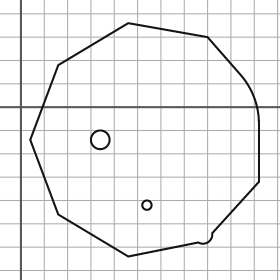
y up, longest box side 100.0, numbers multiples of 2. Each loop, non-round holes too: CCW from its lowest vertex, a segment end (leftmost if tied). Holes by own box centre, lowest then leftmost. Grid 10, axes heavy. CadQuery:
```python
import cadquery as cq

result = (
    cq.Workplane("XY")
    .moveTo(46.0, -64.0)
    .lineTo(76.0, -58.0)
    .threePointArc((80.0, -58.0), (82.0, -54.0))
    .lineTo(102.0, -32.0)
    .lineTo(102.0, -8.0)
    .threePointArc((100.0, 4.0), (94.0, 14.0))
    .lineTo(80.0, 30.0)
    .lineTo(46.0, 36.0)
    .lineTo(16.0, 18.0)
    .lineTo(4.0, -14.0)
    .lineTo(16.0, -46.0)
    .close()
    .moveTo(54.0, -42.0)
    .circle(2.0)
    .moveTo(34.0, -14.0)
    .circle(4.0)
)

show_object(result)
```